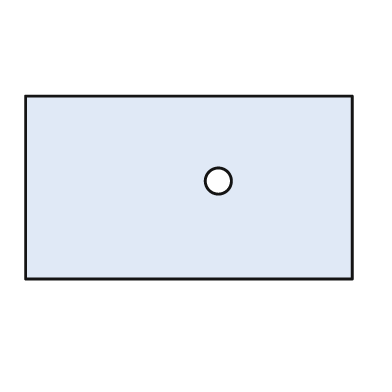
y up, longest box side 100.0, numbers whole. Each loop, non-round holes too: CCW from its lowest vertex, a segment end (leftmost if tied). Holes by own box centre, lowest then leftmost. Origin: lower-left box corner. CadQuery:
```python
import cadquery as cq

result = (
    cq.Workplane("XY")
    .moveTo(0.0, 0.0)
    .lineTo(100.0, 0.0)
    .lineTo(100.0, 56.0)
    .lineTo(0.0, 56.0)
    .close()
    .moveTo(59.0, 30.0)
    .circle(4.0)
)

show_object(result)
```